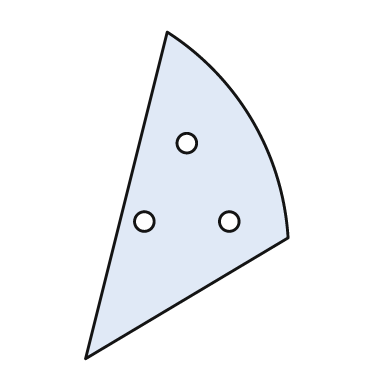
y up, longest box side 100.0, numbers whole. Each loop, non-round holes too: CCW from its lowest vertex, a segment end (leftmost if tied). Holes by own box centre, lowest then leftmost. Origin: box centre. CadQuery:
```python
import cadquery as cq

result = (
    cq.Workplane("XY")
    .moveTo(-31.0, -50.0)
    .lineTo(31.0, -13.0)
    .threePointArc((20.0, 23.0), (-6.0, 50.0))
    .close()
    .moveTo(-13.0, -8.0)
    .circle(3.0)
    .moveTo(13.0, -8.0)
    .circle(3.0)
    .moveTo(0.0, 16.0)
    .circle(3.0)
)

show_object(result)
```